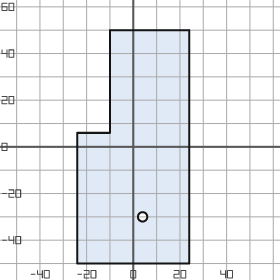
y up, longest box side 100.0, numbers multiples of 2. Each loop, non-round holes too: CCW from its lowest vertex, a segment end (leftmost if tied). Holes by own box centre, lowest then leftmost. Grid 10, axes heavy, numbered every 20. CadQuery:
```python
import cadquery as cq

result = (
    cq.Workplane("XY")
    .moveTo(-24.0, -50.0)
    .lineTo(24.0, -50.0)
    .lineTo(24.0, 50.0)
    .lineTo(-10.0, 50.0)
    .lineTo(-10.0, 6.0)
    .lineTo(-24.0, 6.0)
    .close()
    .moveTo(4.0, -30.0)
    .circle(2.0)
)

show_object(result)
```